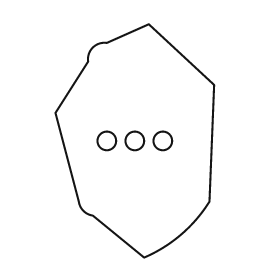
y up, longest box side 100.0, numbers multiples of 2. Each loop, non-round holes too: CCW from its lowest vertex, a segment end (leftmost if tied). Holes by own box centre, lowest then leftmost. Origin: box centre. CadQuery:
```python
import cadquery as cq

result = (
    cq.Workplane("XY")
    .moveTo(4.0, -50.0)
    .threePointArc((20.0, -40.0), (32.0, -26.0))
    .lineTo(34.0, 24.0)
    .lineTo(6.0, 50.0)
    .lineTo(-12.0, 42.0)
    .threePointArc((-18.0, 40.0), (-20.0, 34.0))
    .lineTo(-34.0, 12.0)
    .lineTo(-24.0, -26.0)
    .threePointArc((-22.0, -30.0), (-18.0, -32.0))
    .close()
    .moveTo(-12.0, 0.0)
    .circle(4.0)
    .moveTo(0.0, 0.0)
    .circle(4.0)
    .moveTo(12.0, 0.0)
    .circle(4.0)
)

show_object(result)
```